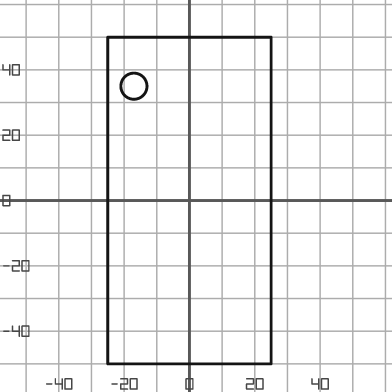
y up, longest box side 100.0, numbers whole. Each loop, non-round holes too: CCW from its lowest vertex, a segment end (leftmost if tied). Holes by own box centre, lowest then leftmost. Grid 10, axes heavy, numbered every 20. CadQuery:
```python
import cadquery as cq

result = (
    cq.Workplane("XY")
    .moveTo(-25.0, -50.0)
    .lineTo(25.0, -50.0)
    .lineTo(25.0, 50.0)
    .lineTo(-25.0, 50.0)
    .close()
    .moveTo(-17.0, 35.0)
    .circle(4.0)
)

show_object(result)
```